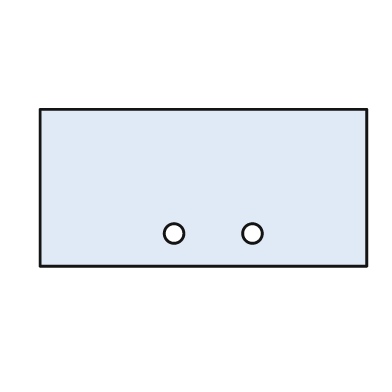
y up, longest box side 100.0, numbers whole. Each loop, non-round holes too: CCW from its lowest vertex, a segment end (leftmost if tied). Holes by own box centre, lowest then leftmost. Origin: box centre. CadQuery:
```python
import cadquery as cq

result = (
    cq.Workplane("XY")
    .moveTo(-50.0, -24.0)
    .lineTo(50.0, -24.0)
    .lineTo(50.0, 24.0)
    .lineTo(-50.0, 24.0)
    .close()
    .moveTo(-9.0, -14.0)
    .circle(3.0)
    .moveTo(15.0, -14.0)
    .circle(3.0)
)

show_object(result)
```